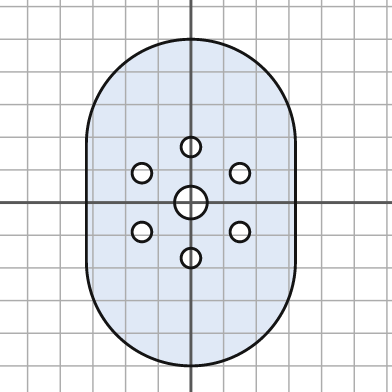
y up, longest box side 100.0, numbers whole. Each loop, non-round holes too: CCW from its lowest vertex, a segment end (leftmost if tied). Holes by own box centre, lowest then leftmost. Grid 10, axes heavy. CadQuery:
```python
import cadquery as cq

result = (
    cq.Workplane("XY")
    .moveTo(-32.0, -18.0)
    .threePointArc((0.0, -50.0), (32.0, -18.0))
    .lineTo(32.0, 18.0)
    .threePointArc((0.0, 50.0), (-32.0, 18.0))
    .close()
    .moveTo(0.0, -17.0)
    .circle(3.0)
    .moveTo(-15.0, -9.0)
    .circle(3.0)
    .moveTo(15.0, -9.0)
    .circle(3.0)
    .moveTo(0.0, 0.0)
    .circle(5.0)
    .moveTo(-15.0, 9.0)
    .circle(3.0)
    .moveTo(15.0, 9.0)
    .circle(3.0)
    .moveTo(0.0, 17.0)
    .circle(3.0)
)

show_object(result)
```